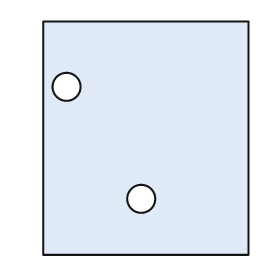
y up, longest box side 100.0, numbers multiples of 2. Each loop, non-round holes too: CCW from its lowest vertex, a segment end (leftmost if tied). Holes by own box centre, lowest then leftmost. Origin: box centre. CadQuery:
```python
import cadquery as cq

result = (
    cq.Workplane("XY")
    .moveTo(-44.0, -50.0)
    .lineTo(44.0, -50.0)
    .lineTo(44.0, 50.0)
    .lineTo(-44.0, 50.0)
    .close()
    .moveTo(-2.0, -26.0)
    .circle(6.0)
    .moveTo(-34.0, 22.0)
    .circle(6.0)
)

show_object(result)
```